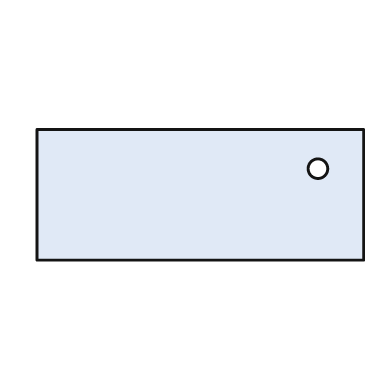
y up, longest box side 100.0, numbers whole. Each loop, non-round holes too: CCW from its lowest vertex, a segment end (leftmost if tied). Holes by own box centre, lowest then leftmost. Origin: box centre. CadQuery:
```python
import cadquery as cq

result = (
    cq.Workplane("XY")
    .moveTo(-50.0, -20.0)
    .lineTo(50.0, -20.0)
    .lineTo(50.0, 20.0)
    .lineTo(-50.0, 20.0)
    .close()
    .moveTo(36.0, 8.0)
    .circle(3.0)
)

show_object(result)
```